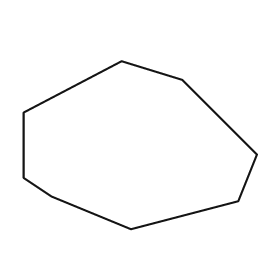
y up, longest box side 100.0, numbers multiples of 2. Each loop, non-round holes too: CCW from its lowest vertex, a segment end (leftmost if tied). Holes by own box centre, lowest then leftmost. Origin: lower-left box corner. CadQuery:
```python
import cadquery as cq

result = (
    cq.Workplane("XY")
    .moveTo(46.0, 0.0)
    .lineTo(92.0, 12.0)
    .lineTo(100.0, 32.0)
    .lineTo(68.0, 64.0)
    .lineTo(42.0, 72.0)
    .lineTo(0.0, 50.0)
    .lineTo(0.0, 22.0)
    .lineTo(12.0, 14.0)
    .close()
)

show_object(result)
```